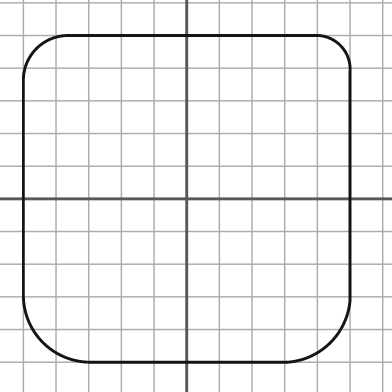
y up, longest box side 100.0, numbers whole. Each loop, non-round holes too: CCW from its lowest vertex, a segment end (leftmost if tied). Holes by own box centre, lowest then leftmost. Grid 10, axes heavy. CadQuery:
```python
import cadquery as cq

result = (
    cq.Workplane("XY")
    .moveTo(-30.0, -50.0)
    .lineTo(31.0, -50.0)
    .threePointArc((44.0, -44.0), (50.0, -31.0))
    .lineTo(50.0, 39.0)
    .threePointArc((47.0, 47.0), (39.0, 50.0))
    .lineTo(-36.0, 50.0)
    .threePointArc((-46.0, 46.0), (-50.0, 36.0))
    .lineTo(-50.0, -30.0)
    .threePointArc((-44.0, -44.0), (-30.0, -50.0))
    .close()
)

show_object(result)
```